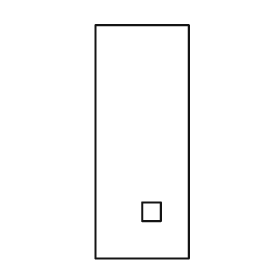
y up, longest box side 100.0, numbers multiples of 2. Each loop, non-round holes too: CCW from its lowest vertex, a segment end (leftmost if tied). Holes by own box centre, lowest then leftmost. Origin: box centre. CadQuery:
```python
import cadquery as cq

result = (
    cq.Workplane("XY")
    .moveTo(-20.0, -50.0)
    .lineTo(20.0, -50.0)
    .lineTo(20.0, 50.0)
    .lineTo(-20.0, 50.0)
    .close()
    .moveTo(0.0, -34.0)
    .lineTo(8.0, -34.0)
    .lineTo(8.0, -26.0)
    .lineTo(0.0, -26.0)
    .close()
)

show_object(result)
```